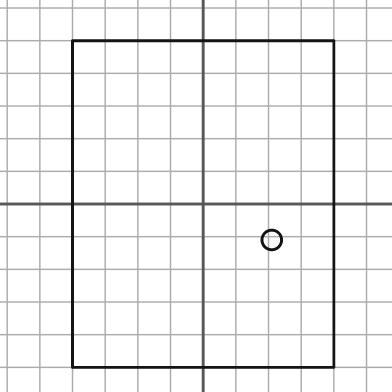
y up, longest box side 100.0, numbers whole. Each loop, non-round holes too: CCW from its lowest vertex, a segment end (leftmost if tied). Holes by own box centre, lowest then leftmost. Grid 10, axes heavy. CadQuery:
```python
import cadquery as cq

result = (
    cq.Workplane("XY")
    .moveTo(-40.0, -50.0)
    .lineTo(40.0, -50.0)
    .lineTo(40.0, 50.0)
    .lineTo(-40.0, 50.0)
    .close()
    .moveTo(21.0, -11.0)
    .circle(3.0)
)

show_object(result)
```